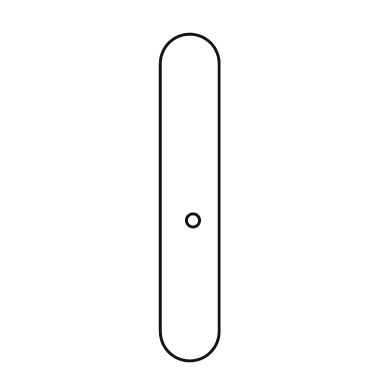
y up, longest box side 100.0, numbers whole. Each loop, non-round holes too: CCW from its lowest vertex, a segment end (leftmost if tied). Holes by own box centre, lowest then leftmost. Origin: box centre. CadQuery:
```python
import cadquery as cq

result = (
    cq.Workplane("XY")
    .moveTo(-9.0, -41.0)
    .threePointArc((0.0, -50.0), (9.0, -41.0))
    .lineTo(9.0, 41.0)
    .threePointArc((0.0, 50.0), (-9.0, 41.0))
    .close()
    .moveTo(1.0, -7.0)
    .circle(2.0)
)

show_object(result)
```